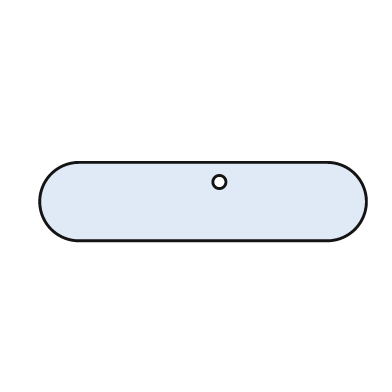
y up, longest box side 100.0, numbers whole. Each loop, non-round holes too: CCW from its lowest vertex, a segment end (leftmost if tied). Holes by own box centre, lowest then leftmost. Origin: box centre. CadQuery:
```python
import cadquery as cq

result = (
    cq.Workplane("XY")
    .moveTo(-38.0, -12.0)
    .lineTo(38.0, -12.0)
    .threePointArc((50.0, 0.0), (38.0, 12.0))
    .lineTo(-38.0, 12.0)
    .threePointArc((-50.0, 0.0), (-38.0, -12.0))
    .close()
    .moveTo(5.0, 6.0)
    .circle(2.0)
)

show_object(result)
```